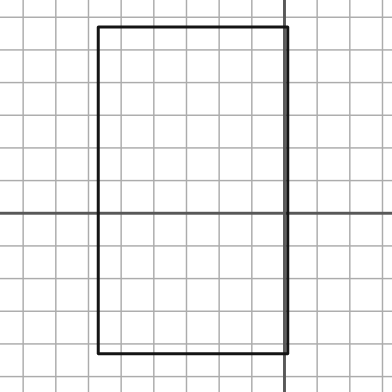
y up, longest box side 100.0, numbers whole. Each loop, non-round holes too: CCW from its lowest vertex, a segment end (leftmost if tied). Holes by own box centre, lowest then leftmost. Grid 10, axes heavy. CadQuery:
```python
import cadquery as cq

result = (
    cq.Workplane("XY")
    .moveTo(-57.0, -43.0)
    .lineTo(1.0, -43.0)
    .lineTo(1.0, 57.0)
    .lineTo(-57.0, 57.0)
    .close()
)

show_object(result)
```